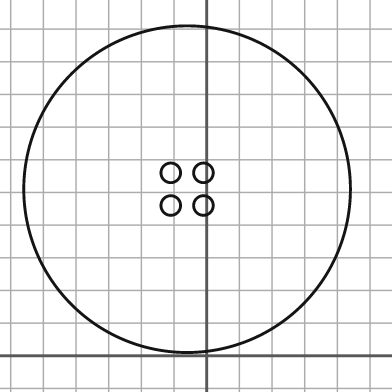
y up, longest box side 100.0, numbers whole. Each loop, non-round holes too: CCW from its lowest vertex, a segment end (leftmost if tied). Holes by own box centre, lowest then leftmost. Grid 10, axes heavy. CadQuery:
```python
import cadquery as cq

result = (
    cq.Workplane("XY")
    .moveTo(-6.0, 51.0)
    .circle(50.0)
    .moveTo(-11.0, 46.0)
    .circle(3.0)
    .moveTo(-1.0, 46.0)
    .circle(3.0)
    .moveTo(-11.0, 56.0)
    .circle(3.0)
    .moveTo(-1.0, 56.0)
    .circle(3.0)
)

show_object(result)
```